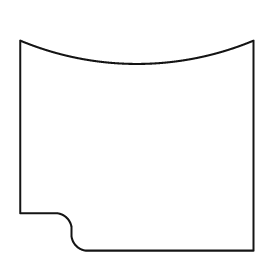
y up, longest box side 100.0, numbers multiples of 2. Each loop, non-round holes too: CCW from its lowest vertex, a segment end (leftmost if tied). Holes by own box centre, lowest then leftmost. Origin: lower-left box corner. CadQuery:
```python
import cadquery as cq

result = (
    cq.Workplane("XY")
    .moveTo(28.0, 0.0)
    .lineTo(100.0, 0.0)
    .lineTo(100.0, 90.0)
    .threePointArc((50.0, 80.0), (0.0, 90.0))
    .lineTo(0.0, 16.0)
    .lineTo(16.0, 16.0)
    .threePointArc((20.0, 14.0), (22.0, 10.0))
    .lineTo(22.0, 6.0)
    .threePointArc((24.0, 2.0), (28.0, 0.0))
    .close()
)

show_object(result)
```